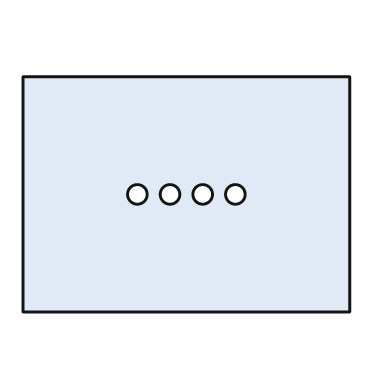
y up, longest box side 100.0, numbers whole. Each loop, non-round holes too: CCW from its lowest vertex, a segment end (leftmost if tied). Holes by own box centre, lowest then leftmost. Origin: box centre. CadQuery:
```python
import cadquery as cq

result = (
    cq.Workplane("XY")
    .moveTo(-50.0, -36.0)
    .lineTo(50.0, -36.0)
    .lineTo(50.0, 36.0)
    .lineTo(-50.0, 36.0)
    .close()
    .moveTo(-15.0, 0.0)
    .circle(3.0)
    .moveTo(-5.0, 0.0)
    .circle(3.0)
    .moveTo(5.0, 0.0)
    .circle(3.0)
    .moveTo(15.0, 0.0)
    .circle(3.0)
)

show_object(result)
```